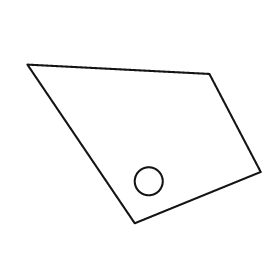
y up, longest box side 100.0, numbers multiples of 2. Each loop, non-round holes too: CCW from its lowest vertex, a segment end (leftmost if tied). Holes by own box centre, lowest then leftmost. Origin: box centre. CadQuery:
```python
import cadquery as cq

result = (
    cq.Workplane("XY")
    .moveTo(-4.0, -34.0)
    .lineTo(50.0, -12.0)
    .lineTo(28.0, 30.0)
    .lineTo(-50.0, 34.0)
    .close()
    .moveTo(2.0, -16.0)
    .circle(6.0)
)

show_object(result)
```